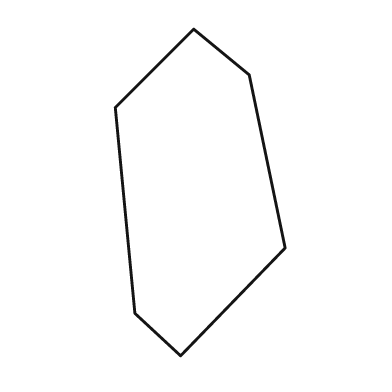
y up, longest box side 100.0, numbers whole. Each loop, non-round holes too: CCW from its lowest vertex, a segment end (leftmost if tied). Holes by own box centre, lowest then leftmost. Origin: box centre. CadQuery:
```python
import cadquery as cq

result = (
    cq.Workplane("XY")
    .moveTo(-6.0, -50.0)
    .lineTo(26.0, -17.0)
    .lineTo(15.0, 36.0)
    .lineTo(-2.0, 50.0)
    .lineTo(-26.0, 26.0)
    .lineTo(-20.0, -37.0)
    .close()
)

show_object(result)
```